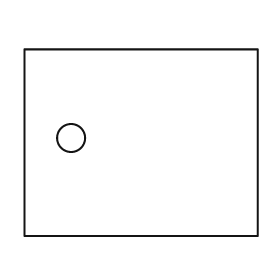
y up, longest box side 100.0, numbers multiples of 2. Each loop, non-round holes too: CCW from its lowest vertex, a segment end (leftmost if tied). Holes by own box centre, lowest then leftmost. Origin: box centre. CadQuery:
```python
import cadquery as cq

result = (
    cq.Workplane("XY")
    .moveTo(-50.0, -40.0)
    .lineTo(50.0, -40.0)
    .lineTo(50.0, 40.0)
    .lineTo(-50.0, 40.0)
    .close()
    .moveTo(-30.0, 2.0)
    .circle(6.0)
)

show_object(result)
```